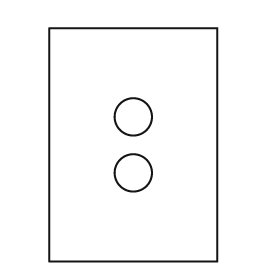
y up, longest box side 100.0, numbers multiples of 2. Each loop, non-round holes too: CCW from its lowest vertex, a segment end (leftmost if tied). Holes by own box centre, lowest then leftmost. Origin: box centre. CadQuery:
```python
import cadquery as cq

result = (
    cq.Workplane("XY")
    .moveTo(-36.0, -50.0)
    .lineTo(36.0, -50.0)
    .lineTo(36.0, 50.0)
    .lineTo(-36.0, 50.0)
    .close()
    .moveTo(0.0, -12.0)
    .circle(8.0)
    .moveTo(0.0, 12.0)
    .circle(8.0)
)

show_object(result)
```